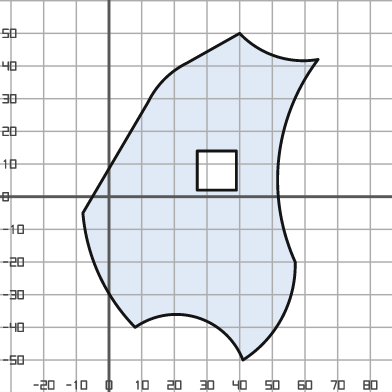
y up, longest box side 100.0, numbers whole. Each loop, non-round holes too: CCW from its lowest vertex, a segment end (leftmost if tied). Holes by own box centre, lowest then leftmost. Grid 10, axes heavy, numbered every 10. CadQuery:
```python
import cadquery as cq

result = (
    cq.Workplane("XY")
    .moveTo(41.0, -50.0)
    .threePointArc((53.0, -37.0), (57.0, -20.0))
    .threePointArc((52.0, 12.0), (64.0, 42.0))
    .threePointArc((51.0, 43.0), (40.0, 50.0))
    .lineTo(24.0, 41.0)
    .threePointArc((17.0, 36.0), (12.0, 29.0))
    .lineTo(-8.0, -5.0)
    .threePointArc((-3.0, -24.0), (8.0, -40.0))
    .threePointArc((27.0, -37.0), (41.0, -50.0))
    .close()
    .moveTo(27.0, 2.0)
    .lineTo(39.0, 2.0)
    .lineTo(39.0, 14.0)
    .lineTo(27.0, 14.0)
    .close()
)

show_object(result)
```